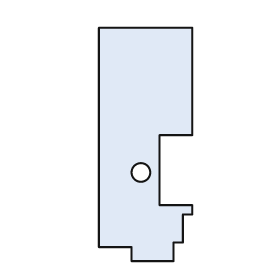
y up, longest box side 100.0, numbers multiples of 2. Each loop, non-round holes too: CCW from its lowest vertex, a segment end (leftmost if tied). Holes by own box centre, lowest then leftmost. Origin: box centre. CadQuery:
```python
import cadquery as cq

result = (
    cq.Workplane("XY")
    .moveTo(-6.0, -50.0)
    .lineTo(12.0, -50.0)
    .lineTo(12.0, -42.0)
    .lineTo(16.0, -42.0)
    .lineTo(16.0, -30.0)
    .lineTo(20.0, -30.0)
    .lineTo(20.0, -26.0)
    .lineTo(6.0, -26.0)
    .lineTo(6.0, 4.0)
    .lineTo(20.0, 4.0)
    .lineTo(20.0, 50.0)
    .lineTo(-20.0, 50.0)
    .lineTo(-20.0, -44.0)
    .lineTo(-6.0, -44.0)
    .close()
    .moveTo(-2.0, -12.0)
    .circle(4.0)
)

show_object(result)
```